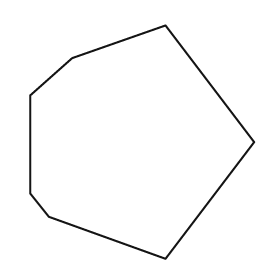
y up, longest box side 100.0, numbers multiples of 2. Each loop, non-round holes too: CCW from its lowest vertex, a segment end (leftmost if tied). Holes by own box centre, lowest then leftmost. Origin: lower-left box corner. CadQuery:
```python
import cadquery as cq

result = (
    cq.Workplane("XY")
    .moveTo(58.0, 0.0)
    .lineTo(96.0, 50.0)
    .lineTo(58.0, 100.0)
    .lineTo(18.0, 86.0)
    .lineTo(0.0, 70.0)
    .lineTo(0.0, 28.0)
    .lineTo(8.0, 18.0)
    .close()
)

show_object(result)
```